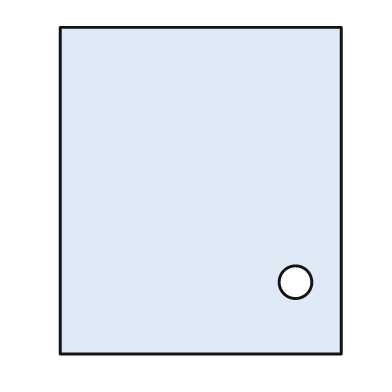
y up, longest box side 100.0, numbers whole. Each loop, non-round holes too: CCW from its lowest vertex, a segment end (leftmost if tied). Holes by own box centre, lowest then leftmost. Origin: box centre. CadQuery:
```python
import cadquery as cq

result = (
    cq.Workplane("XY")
    .moveTo(-43.0, -50.0)
    .lineTo(43.0, -50.0)
    .lineTo(43.0, 50.0)
    .lineTo(-43.0, 50.0)
    .close()
    .moveTo(29.0, -28.0)
    .circle(5.0)
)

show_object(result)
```